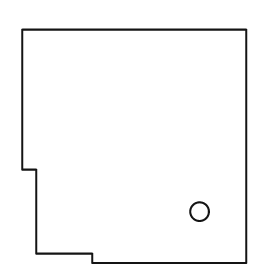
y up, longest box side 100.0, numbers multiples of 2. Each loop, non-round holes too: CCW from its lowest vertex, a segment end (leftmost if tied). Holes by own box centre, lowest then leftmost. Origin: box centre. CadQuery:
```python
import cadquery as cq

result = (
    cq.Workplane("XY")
    .moveTo(-18.0, -50.0)
    .lineTo(48.0, -50.0)
    .lineTo(48.0, 50.0)
    .lineTo(-48.0, 50.0)
    .lineTo(-48.0, -10.0)
    .lineTo(-42.0, -10.0)
    .lineTo(-42.0, -46.0)
    .lineTo(-18.0, -46.0)
    .close()
    .moveTo(28.0, -28.0)
    .circle(4.0)
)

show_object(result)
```